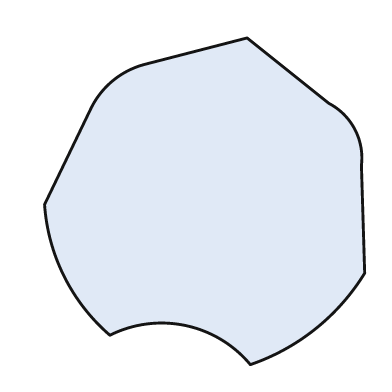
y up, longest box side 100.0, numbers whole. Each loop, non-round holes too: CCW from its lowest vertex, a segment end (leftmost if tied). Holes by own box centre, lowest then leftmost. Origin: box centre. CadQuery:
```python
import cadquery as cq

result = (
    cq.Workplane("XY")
    .moveTo(14.0, -50.0)
    .threePointArc((34.0, -39.0), (49.0, -22.0))
    .lineTo(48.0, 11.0)
    .threePointArc((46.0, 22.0), (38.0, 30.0))
    .lineTo(13.0, 50.0)
    .lineTo(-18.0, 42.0)
    .threePointArc((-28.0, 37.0), (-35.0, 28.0))
    .lineTo(-49.0, -1.0)
    .threePointArc((-43.0, -23.0), (-29.0, -41.0))
    .threePointArc((-6.0, -38.0), (14.0, -50.0))
    .close()
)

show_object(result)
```